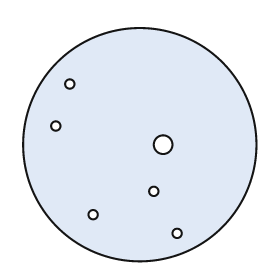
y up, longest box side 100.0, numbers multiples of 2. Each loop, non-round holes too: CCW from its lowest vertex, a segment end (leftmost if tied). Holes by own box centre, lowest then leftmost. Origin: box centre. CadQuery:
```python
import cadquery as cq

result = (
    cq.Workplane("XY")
    .moveTo(0.0, 0.0)
    .circle(50.0)
    .moveTo(16.0, -38.0)
    .circle(2.0)
    .moveTo(-20.0, -30.0)
    .circle(2.0)
    .moveTo(6.0, -20.0)
    .circle(2.0)
    .moveTo(10.0, 0.0)
    .circle(4.0)
    .moveTo(-36.0, 8.0)
    .circle(2.0)
    .moveTo(-30.0, 26.0)
    .circle(2.0)
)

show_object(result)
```